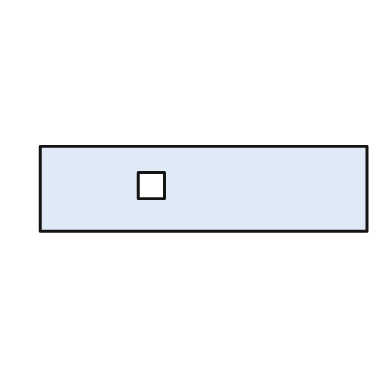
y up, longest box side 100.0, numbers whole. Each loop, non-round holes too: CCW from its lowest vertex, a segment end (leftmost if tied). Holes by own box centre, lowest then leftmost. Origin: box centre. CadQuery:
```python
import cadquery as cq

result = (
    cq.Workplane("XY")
    .moveTo(-50.0, -13.0)
    .lineTo(50.0, -13.0)
    .lineTo(50.0, 13.0)
    .lineTo(-50.0, 13.0)
    .close()
    .moveTo(-20.0, -3.0)
    .lineTo(-12.0, -3.0)
    .lineTo(-12.0, 5.0)
    .lineTo(-20.0, 5.0)
    .close()
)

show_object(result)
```